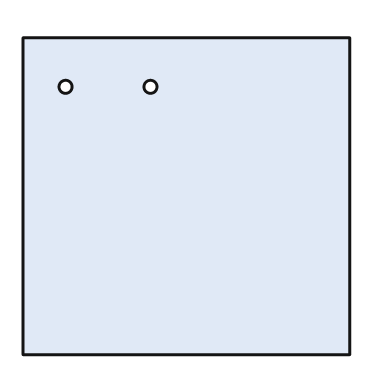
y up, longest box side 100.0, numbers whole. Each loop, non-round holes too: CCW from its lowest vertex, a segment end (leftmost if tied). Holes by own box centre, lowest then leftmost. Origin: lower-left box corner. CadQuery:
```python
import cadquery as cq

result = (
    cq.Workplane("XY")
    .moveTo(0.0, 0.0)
    .lineTo(100.0, 0.0)
    .lineTo(100.0, 97.0)
    .lineTo(0.0, 97.0)
    .close()
    .moveTo(13.0, 82.0)
    .circle(2.0)
    .moveTo(39.0, 82.0)
    .circle(2.0)
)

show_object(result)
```